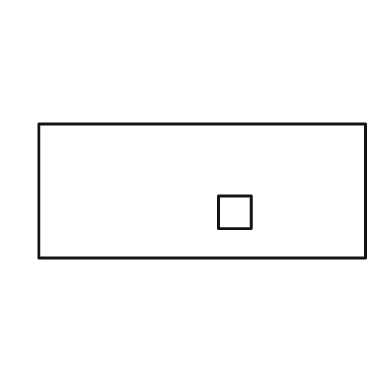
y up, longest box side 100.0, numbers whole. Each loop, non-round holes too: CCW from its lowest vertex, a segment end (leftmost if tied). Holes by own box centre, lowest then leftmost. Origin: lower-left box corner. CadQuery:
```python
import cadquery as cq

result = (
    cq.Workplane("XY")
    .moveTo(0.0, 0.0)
    .lineTo(100.0, 0.0)
    .lineTo(100.0, 41.0)
    .lineTo(0.0, 41.0)
    .close()
    .moveTo(55.0, 9.0)
    .lineTo(65.0, 9.0)
    .lineTo(65.0, 19.0)
    .lineTo(55.0, 19.0)
    .close()
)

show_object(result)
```